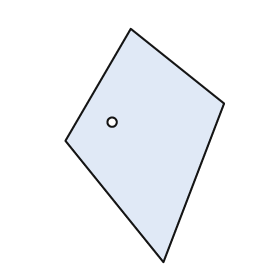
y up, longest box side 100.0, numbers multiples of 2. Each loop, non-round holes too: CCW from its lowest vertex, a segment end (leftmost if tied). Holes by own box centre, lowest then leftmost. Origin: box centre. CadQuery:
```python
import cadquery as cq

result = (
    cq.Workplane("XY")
    .moveTo(8.0, -50.0)
    .lineTo(34.0, 18.0)
    .lineTo(-6.0, 50.0)
    .lineTo(-34.0, 2.0)
    .close()
    .moveTo(-14.0, 10.0)
    .circle(2.0)
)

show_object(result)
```